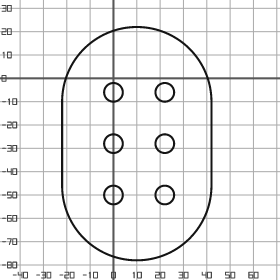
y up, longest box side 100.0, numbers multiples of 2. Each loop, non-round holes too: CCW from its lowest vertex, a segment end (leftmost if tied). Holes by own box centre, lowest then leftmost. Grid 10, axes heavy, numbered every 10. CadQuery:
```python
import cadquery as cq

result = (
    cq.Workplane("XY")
    .moveTo(-22.0, -46.0)
    .threePointArc((10.0, -78.0), (42.0, -46.0))
    .lineTo(42.0, -10.0)
    .threePointArc((10.0, 22.0), (-22.0, -10.0))
    .close()
    .moveTo(0.0, -50.0)
    .circle(4.0)
    .moveTo(22.0, -50.0)
    .circle(4.0)
    .moveTo(0.0, -28.0)
    .circle(4.0)
    .moveTo(22.0, -28.0)
    .circle(4.0)
    .moveTo(0.0, -6.0)
    .circle(4.0)
    .moveTo(22.0, -6.0)
    .circle(4.0)
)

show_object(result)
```